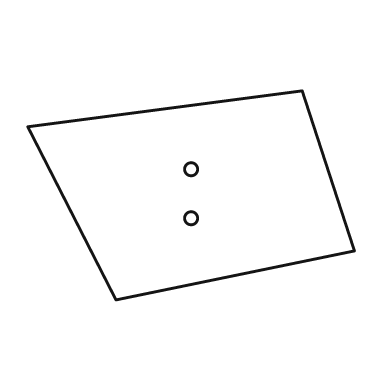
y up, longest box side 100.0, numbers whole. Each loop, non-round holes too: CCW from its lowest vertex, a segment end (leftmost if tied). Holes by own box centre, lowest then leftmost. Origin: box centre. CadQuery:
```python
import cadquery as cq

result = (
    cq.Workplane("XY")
    .moveTo(-23.0, -32.0)
    .lineTo(50.0, -17.0)
    .lineTo(34.0, 32.0)
    .lineTo(-50.0, 21.0)
    .close()
    .moveTo(0.0, -7.0)
    .circle(2.0)
    .moveTo(0.0, 8.0)
    .circle(2.0)
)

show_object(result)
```